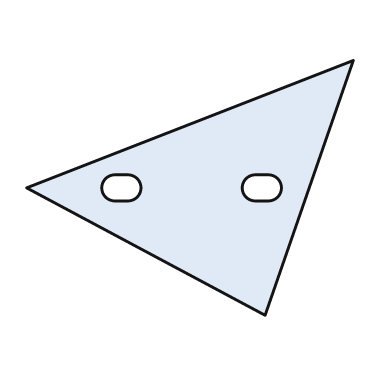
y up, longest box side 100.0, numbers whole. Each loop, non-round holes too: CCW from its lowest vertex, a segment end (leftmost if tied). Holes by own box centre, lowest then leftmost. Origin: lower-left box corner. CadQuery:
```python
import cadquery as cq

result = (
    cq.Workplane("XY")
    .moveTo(73.0, 0.0)
    .lineTo(100.0, 78.0)
    .lineTo(0.0, 39.0)
    .close()
    .moveTo(27.0, 35.0)
    .lineTo(31.0, 35.0)
    .threePointArc((35.0, 39.0), (31.0, 43.0))
    .lineTo(27.0, 43.0)
    .threePointArc((23.0, 39.0), (27.0, 35.0))
    .close()
    .moveTo(70.0, 35.0)
    .lineTo(74.0, 35.0)
    .threePointArc((78.0, 39.0), (74.0, 43.0))
    .lineTo(70.0, 43.0)
    .threePointArc((66.0, 39.0), (70.0, 35.0))
    .close()
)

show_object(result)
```